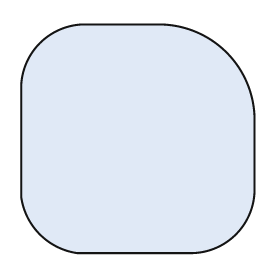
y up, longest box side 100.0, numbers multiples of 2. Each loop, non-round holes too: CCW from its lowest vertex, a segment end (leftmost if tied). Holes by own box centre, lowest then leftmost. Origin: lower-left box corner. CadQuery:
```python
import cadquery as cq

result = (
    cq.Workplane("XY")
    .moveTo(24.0, 0.0)
    .lineTo(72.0, 0.0)
    .threePointArc((92.0, 8.0), (100.0, 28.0))
    .lineTo(100.0, 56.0)
    .threePointArc((88.0, 86.0), (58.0, 98.0))
    .lineTo(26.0, 98.0)
    .threePointArc((8.0, 90.0), (0.0, 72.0))
    .lineTo(0.0, 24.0)
    .threePointArc((8.0, 8.0), (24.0, 0.0))
    .close()
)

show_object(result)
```